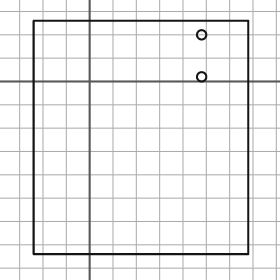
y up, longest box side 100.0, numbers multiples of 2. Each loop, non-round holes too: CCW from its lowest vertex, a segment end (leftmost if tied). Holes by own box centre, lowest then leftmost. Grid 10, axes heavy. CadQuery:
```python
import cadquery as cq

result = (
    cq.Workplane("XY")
    .moveTo(-24.0, -74.0)
    .lineTo(68.0, -74.0)
    .lineTo(68.0, 26.0)
    .lineTo(-24.0, 26.0)
    .close()
    .moveTo(48.0, 2.0)
    .circle(2.0)
    .moveTo(48.0, 20.0)
    .circle(2.0)
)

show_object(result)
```